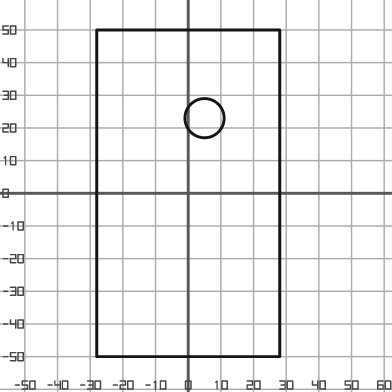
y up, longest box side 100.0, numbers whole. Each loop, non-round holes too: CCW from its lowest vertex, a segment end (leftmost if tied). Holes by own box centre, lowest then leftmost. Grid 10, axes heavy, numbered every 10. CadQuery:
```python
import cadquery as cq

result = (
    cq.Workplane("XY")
    .moveTo(-28.0, -50.0)
    .lineTo(28.0, -50.0)
    .lineTo(28.0, 50.0)
    .lineTo(-28.0, 50.0)
    .close()
    .moveTo(5.0, 23.0)
    .circle(6.0)
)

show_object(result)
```